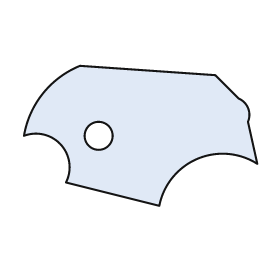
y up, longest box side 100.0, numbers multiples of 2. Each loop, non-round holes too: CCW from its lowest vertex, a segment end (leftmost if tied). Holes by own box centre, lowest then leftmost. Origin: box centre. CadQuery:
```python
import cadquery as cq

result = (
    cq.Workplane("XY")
    .moveTo(8.0, -30.0)
    .threePointArc((24.0, -10.0), (50.0, -12.0))
    .lineTo(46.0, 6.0)
    .threePointArc((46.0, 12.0), (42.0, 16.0))
    .lineTo(32.0, 26.0)
    .lineTo(-26.0, 30.0)
    .threePointArc((-42.0, 18.0), (-50.0, 0.0))
    .threePointArc((-34.0, -4.0), (-32.0, -20.0))
    .close()
    .moveTo(-18.0, 0.0)
    .circle(6.0)
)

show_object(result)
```